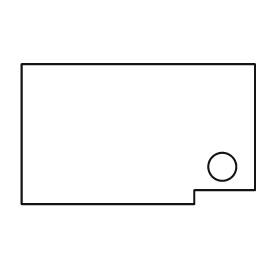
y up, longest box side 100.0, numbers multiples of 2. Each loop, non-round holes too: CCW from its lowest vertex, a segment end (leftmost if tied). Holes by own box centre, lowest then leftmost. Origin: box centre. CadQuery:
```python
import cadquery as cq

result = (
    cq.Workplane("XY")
    .moveTo(-50.0, -30.0)
    .lineTo(24.0, -30.0)
    .lineTo(24.0, -24.0)
    .lineTo(50.0, -24.0)
    .lineTo(50.0, 30.0)
    .lineTo(-50.0, 30.0)
    .close()
    .moveTo(36.0, -14.0)
    .circle(6.0)
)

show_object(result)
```